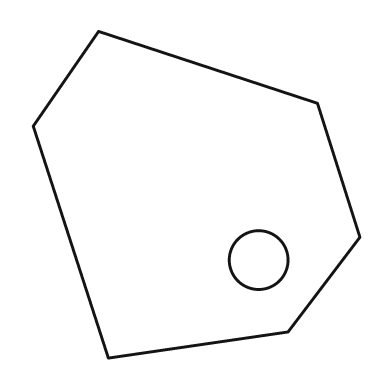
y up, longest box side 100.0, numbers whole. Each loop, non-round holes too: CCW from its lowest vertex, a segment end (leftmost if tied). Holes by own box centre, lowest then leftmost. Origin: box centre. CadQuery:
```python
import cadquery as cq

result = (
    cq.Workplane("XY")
    .moveTo(-27.0, -50.0)
    .lineTo(28.0, -42.0)
    .lineTo(50.0, -13.0)
    .lineTo(37.0, 28.0)
    .lineTo(-30.0, 50.0)
    .lineTo(-50.0, 21.0)
    .close()
    .moveTo(19.0, -20.0)
    .circle(9.0)
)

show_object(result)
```